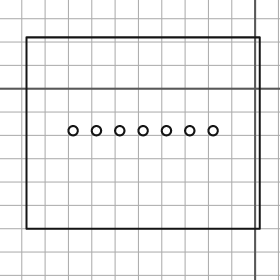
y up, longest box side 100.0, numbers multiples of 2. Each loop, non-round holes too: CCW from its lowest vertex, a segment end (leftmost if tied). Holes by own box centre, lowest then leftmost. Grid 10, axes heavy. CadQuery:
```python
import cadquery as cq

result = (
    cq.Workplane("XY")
    .moveTo(-98.0, -60.0)
    .lineTo(2.0, -60.0)
    .lineTo(2.0, 22.0)
    .lineTo(-98.0, 22.0)
    .close()
    .moveTo(-78.0, -18.0)
    .circle(2.0)
    .moveTo(-68.0, -18.0)
    .circle(2.0)
    .moveTo(-58.0, -18.0)
    .circle(2.0)
    .moveTo(-48.0, -18.0)
    .circle(2.0)
    .moveTo(-38.0, -18.0)
    .circle(2.0)
    .moveTo(-28.0, -18.0)
    .circle(2.0)
    .moveTo(-18.0, -18.0)
    .circle(2.0)
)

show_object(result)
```